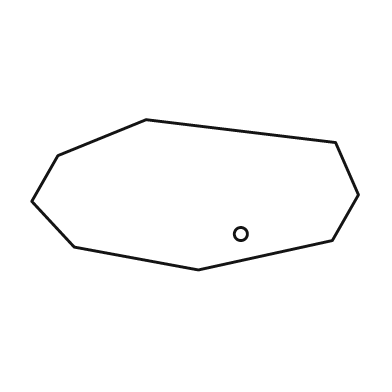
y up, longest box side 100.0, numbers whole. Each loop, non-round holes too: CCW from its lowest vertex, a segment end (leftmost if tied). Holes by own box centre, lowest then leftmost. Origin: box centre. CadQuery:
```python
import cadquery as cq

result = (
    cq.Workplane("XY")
    .moveTo(1.0, -23.0)
    .lineTo(42.0, -14.0)
    .lineTo(50.0, 0.0)
    .lineTo(43.0, 16.0)
    .lineTo(-15.0, 23.0)
    .lineTo(-42.0, 12.0)
    .lineTo(-50.0, -2.0)
    .lineTo(-37.0, -16.0)
    .close()
    .moveTo(14.0, -12.0)
    .circle(2.0)
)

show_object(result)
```